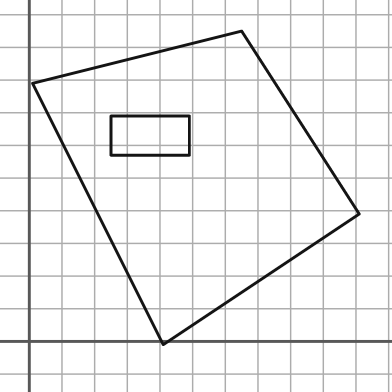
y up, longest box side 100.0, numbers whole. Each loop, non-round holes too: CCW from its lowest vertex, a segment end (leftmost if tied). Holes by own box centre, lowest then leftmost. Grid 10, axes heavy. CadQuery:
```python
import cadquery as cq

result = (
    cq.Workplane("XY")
    .moveTo(41.0, -1.0)
    .lineTo(101.0, 39.0)
    .lineTo(65.0, 95.0)
    .lineTo(1.0, 79.0)
    .close()
    .moveTo(25.0, 57.0)
    .lineTo(49.0, 57.0)
    .lineTo(49.0, 69.0)
    .lineTo(25.0, 69.0)
    .close()
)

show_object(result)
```